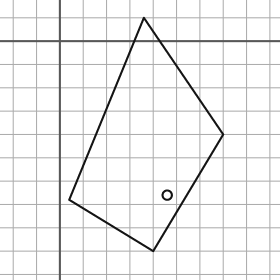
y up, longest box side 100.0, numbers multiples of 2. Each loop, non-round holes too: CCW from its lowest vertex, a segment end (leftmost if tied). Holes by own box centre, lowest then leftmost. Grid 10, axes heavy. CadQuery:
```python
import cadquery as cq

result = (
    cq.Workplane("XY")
    .moveTo(40.0, -90.0)
    .lineTo(70.0, -40.0)
    .lineTo(36.0, 10.0)
    .lineTo(4.0, -68.0)
    .close()
    .moveTo(46.0, -66.0)
    .circle(2.0)
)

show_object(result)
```